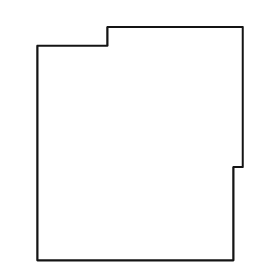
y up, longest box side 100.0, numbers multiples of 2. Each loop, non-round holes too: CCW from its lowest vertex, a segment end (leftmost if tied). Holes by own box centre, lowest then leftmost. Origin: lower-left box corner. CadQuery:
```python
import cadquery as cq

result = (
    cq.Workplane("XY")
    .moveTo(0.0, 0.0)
    .lineTo(84.0, 0.0)
    .lineTo(84.0, 40.0)
    .lineTo(88.0, 40.0)
    .lineTo(88.0, 100.0)
    .lineTo(30.0, 100.0)
    .lineTo(30.0, 92.0)
    .lineTo(0.0, 92.0)
    .close()
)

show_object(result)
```